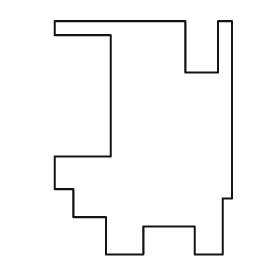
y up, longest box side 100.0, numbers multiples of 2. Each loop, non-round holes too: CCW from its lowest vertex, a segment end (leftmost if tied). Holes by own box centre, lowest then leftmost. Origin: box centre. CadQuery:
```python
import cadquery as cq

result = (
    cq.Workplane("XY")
    .moveTo(-16.0, -50.0)
    .lineTo(0.0, -50.0)
    .lineTo(0.0, -38.0)
    .lineTo(22.0, -38.0)
    .lineTo(22.0, -50.0)
    .lineTo(34.0, -50.0)
    .lineTo(34.0, -26.0)
    .lineTo(38.0, -26.0)
    .lineTo(38.0, 50.0)
    .lineTo(32.0, 50.0)
    .lineTo(32.0, 28.0)
    .lineTo(18.0, 28.0)
    .lineTo(18.0, 50.0)
    .lineTo(-38.0, 50.0)
    .lineTo(-38.0, 44.0)
    .lineTo(-14.0, 44.0)
    .lineTo(-14.0, -8.0)
    .lineTo(-38.0, -8.0)
    .lineTo(-38.0, -22.0)
    .lineTo(-30.0, -22.0)
    .lineTo(-30.0, -34.0)
    .lineTo(-16.0, -34.0)
    .close()
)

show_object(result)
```